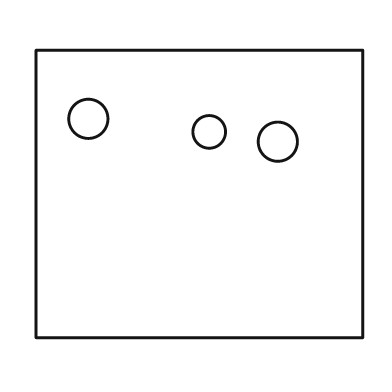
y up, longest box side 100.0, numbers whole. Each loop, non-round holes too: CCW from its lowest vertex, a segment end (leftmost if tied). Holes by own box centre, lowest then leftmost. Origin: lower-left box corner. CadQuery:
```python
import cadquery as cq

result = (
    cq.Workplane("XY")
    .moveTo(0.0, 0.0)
    .lineTo(100.0, 0.0)
    .lineTo(100.0, 88.0)
    .lineTo(0.0, 88.0)
    .close()
    .moveTo(74.0, 60.0)
    .circle(6.0)
    .moveTo(53.0, 63.0)
    .circle(5.0)
    .moveTo(16.0, 67.0)
    .circle(6.0)
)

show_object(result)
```